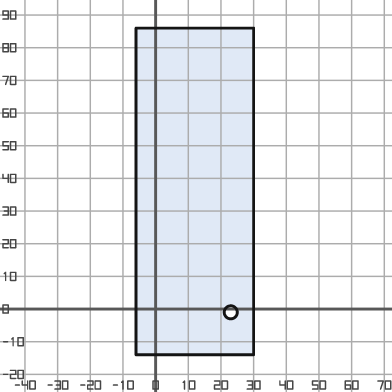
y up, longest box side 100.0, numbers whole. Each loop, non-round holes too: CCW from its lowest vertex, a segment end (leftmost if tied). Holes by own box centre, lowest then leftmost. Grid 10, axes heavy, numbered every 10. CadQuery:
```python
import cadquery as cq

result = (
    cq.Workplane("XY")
    .moveTo(-6.0, -14.0)
    .lineTo(30.0, -14.0)
    .lineTo(30.0, 86.0)
    .lineTo(-6.0, 86.0)
    .close()
    .moveTo(23.0, -1.0)
    .circle(2.0)
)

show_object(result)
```